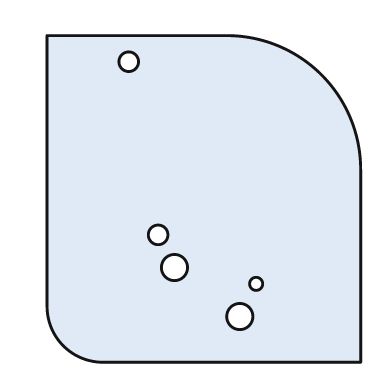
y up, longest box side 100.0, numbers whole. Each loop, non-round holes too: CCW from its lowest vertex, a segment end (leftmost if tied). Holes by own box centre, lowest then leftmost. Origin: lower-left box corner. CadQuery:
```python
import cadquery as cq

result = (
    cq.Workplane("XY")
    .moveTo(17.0, 0.0)
    .lineTo(96.0, 0.0)
    .lineTo(96.0, 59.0)
    .threePointArc((84.0, 88.0), (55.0, 100.0))
    .lineTo(0.0, 100.0)
    .lineTo(0.0, 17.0)
    .threePointArc((5.0, 5.0), (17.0, 0.0))
    .close()
    .moveTo(59.0, 14.0)
    .circle(4.0)
    .moveTo(64.0, 24.0)
    .circle(2.0)
    .moveTo(39.0, 29.0)
    .circle(4.0)
    .moveTo(34.0, 39.0)
    .circle(3.0)
    .moveTo(25.0, 92.0)
    .circle(3.0)
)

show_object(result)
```